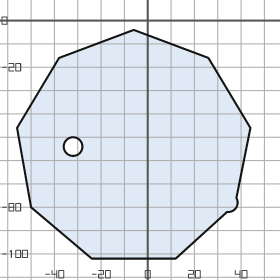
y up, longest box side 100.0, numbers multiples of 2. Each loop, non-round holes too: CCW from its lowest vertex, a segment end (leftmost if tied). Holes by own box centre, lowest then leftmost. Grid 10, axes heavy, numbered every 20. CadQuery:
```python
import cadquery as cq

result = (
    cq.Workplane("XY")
    .moveTo(-24.0, -102.0)
    .lineTo(12.0, -102.0)
    .lineTo(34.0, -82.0)
    .threePointArc((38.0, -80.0), (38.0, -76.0))
    .lineTo(44.0, -46.0)
    .lineTo(26.0, -16.0)
    .lineTo(-6.0, -4.0)
    .lineTo(-38.0, -16.0)
    .lineTo(-56.0, -46.0)
    .lineTo(-50.0, -80.0)
    .close()
    .moveTo(-32.0, -54.0)
    .circle(4.0)
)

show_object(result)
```